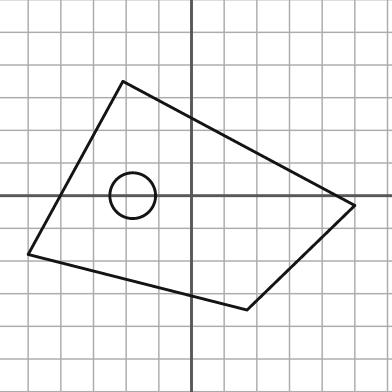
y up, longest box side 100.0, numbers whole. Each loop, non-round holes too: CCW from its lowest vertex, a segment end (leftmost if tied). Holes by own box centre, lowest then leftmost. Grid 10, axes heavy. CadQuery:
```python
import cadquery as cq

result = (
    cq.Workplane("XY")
    .moveTo(17.0, -35.0)
    .lineTo(50.0, -3.0)
    .lineTo(-21.0, 35.0)
    .lineTo(-50.0, -18.0)
    .close()
    .moveTo(-18.0, 0.0)
    .circle(7.0)
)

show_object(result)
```